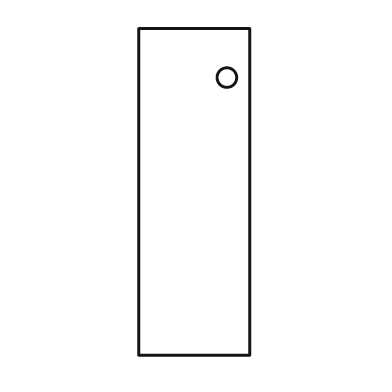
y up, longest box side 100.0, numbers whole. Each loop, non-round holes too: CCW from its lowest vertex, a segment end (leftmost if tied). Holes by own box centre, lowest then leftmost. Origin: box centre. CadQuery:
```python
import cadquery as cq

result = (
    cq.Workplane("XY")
    .moveTo(-17.0, -50.0)
    .lineTo(17.0, -50.0)
    .lineTo(17.0, 50.0)
    .lineTo(-17.0, 50.0)
    .close()
    .moveTo(10.0, 35.0)
    .circle(3.0)
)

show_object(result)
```